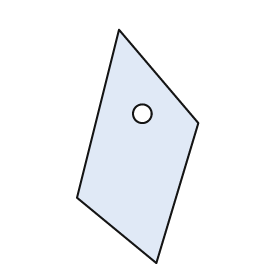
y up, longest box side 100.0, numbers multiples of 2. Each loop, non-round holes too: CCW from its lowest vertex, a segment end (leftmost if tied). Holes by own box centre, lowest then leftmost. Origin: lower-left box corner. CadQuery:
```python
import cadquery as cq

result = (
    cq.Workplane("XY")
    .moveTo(34.0, 0.0)
    .lineTo(52.0, 60.0)
    .lineTo(18.0, 100.0)
    .lineTo(0.0, 28.0)
    .close()
    .moveTo(28.0, 64.0)
    .circle(4.0)
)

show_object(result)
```